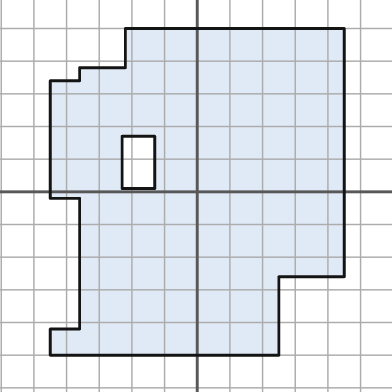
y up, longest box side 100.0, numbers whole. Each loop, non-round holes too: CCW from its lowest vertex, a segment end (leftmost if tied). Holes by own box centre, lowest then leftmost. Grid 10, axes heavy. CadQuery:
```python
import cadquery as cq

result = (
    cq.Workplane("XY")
    .moveTo(-45.0, -50.0)
    .lineTo(25.0, -50.0)
    .lineTo(25.0, -26.0)
    .lineTo(45.0, -26.0)
    .lineTo(45.0, 50.0)
    .lineTo(-22.0, 50.0)
    .lineTo(-22.0, 38.0)
    .lineTo(-36.0, 38.0)
    .lineTo(-36.0, 34.0)
    .lineTo(-45.0, 34.0)
    .lineTo(-45.0, -2.0)
    .lineTo(-36.0, -2.0)
    .lineTo(-36.0, -42.0)
    .lineTo(-45.0, -42.0)
    .close()
    .moveTo(-23.0, 1.0)
    .lineTo(-13.0, 1.0)
    .lineTo(-13.0, 17.0)
    .lineTo(-23.0, 17.0)
    .close()
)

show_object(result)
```